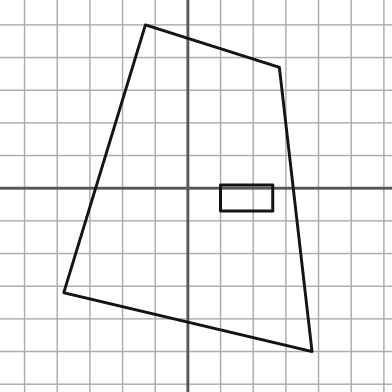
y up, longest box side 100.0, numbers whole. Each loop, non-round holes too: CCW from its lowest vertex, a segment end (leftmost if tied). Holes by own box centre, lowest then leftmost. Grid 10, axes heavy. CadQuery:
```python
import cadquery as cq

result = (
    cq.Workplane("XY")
    .moveTo(38.0, -50.0)
    .lineTo(28.0, 37.0)
    .lineTo(-13.0, 50.0)
    .lineTo(-38.0, -32.0)
    .close()
    .moveTo(10.0, -7.0)
    .lineTo(26.0, -7.0)
    .lineTo(26.0, 1.0)
    .lineTo(10.0, 1.0)
    .close()
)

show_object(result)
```